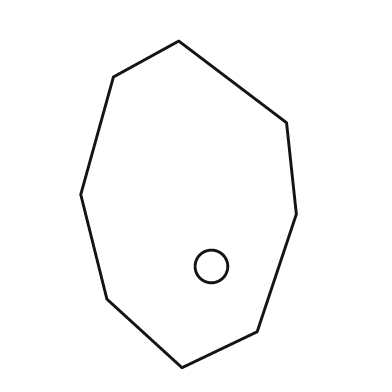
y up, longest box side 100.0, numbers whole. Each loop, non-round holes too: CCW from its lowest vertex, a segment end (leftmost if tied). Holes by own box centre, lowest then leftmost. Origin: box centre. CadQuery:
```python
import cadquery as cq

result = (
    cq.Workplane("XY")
    .moveTo(-2.0, -50.0)
    .lineTo(21.0, -39.0)
    .lineTo(33.0, -3.0)
    .lineTo(30.0, 25.0)
    .lineTo(-3.0, 50.0)
    .lineTo(-23.0, 39.0)
    .lineTo(-33.0, 3.0)
    .lineTo(-25.0, -29.0)
    .close()
    .moveTo(7.0, -19.0)
    .circle(5.0)
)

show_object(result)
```